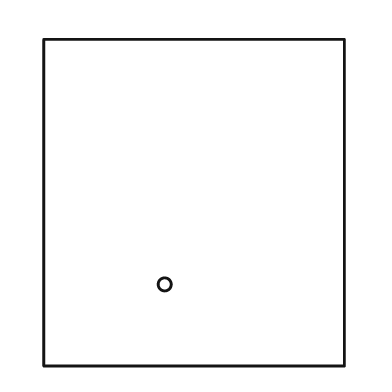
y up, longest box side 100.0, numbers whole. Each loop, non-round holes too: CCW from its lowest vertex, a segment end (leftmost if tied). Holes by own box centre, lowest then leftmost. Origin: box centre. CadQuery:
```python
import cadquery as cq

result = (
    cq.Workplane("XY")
    .moveTo(-46.0, -50.0)
    .lineTo(46.0, -50.0)
    .lineTo(46.0, 50.0)
    .lineTo(-46.0, 50.0)
    .close()
    .moveTo(-9.0, -25.0)
    .circle(2.0)
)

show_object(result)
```